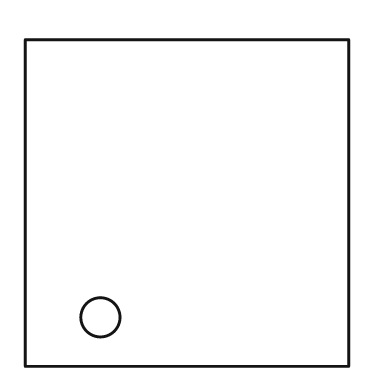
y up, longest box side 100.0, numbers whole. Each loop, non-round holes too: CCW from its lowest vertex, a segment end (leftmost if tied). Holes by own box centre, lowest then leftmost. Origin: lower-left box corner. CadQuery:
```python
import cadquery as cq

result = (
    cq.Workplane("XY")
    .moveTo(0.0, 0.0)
    .lineTo(99.0, 0.0)
    .lineTo(99.0, 100.0)
    .lineTo(0.0, 100.0)
    .close()
    .moveTo(23.0, 15.0)
    .circle(6.0)
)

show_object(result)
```